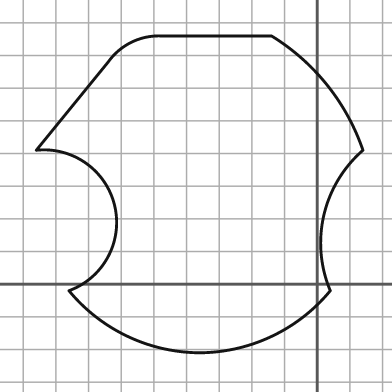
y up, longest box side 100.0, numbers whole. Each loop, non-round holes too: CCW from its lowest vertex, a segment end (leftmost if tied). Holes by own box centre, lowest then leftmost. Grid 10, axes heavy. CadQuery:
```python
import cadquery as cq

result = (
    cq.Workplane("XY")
    .moveTo(-36.0, -21.0)
    .threePointArc((-14.0, -16.0), (4.0, -2.0))
    .threePointArc((2.0, 21.0), (14.0, 41.0))
    .threePointArc((3.0, 61.0), (-14.0, 76.0))
    .lineTo(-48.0, 76.0)
    .threePointArc((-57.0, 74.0), (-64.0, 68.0))
    .lineTo(-86.0, 41.0)
    .threePointArc((-62.0, 24.0), (-76.0, -2.0))
    .threePointArc((-58.0, -16.0), (-36.0, -21.0))
    .close()
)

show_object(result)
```